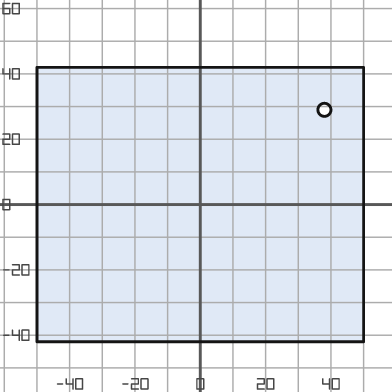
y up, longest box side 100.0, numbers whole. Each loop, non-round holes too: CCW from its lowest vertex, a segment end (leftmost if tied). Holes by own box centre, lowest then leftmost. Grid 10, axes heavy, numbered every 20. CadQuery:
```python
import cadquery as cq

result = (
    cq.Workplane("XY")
    .moveTo(-50.0, -42.0)
    .lineTo(50.0, -42.0)
    .lineTo(50.0, 42.0)
    .lineTo(-50.0, 42.0)
    .close()
    .moveTo(38.0, 29.0)
    .circle(2.0)
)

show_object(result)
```